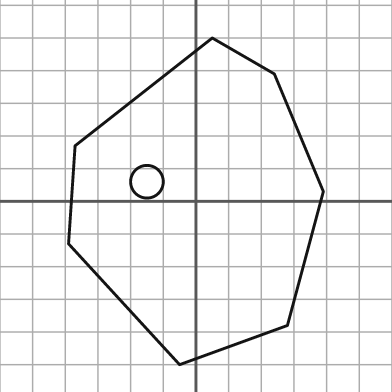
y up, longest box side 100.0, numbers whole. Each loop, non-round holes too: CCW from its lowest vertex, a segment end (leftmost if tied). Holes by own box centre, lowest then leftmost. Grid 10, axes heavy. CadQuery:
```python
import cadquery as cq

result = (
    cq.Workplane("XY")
    .moveTo(-5.0, -50.0)
    .lineTo(28.0, -38.0)
    .lineTo(39.0, 3.0)
    .lineTo(24.0, 39.0)
    .lineTo(5.0, 50.0)
    .lineTo(-37.0, 17.0)
    .lineTo(-39.0, -13.0)
    .close()
    .moveTo(-15.0, 6.0)
    .circle(5.0)
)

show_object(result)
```